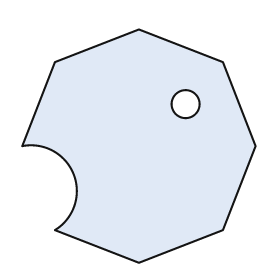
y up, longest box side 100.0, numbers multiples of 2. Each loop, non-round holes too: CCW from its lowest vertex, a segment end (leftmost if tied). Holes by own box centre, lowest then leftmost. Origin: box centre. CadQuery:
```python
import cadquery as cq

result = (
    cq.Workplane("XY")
    .moveTo(0.0, -50.0)
    .lineTo(36.0, -36.0)
    .lineTo(50.0, 0.0)
    .lineTo(36.0, 36.0)
    .lineTo(0.0, 50.0)
    .lineTo(-36.0, 36.0)
    .lineTo(-50.0, 0.0)
    .threePointArc((-28.0, -12.0), (-36.0, -36.0))
    .close()
    .moveTo(20.0, 18.0)
    .circle(6.0)
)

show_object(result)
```